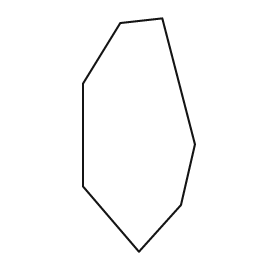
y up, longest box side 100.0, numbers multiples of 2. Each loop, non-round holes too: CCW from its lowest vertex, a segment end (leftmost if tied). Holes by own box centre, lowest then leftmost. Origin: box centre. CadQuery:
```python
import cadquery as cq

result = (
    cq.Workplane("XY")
    .moveTo(0.0, -50.0)
    .lineTo(18.0, -30.0)
    .lineTo(24.0, -4.0)
    .lineTo(10.0, 50.0)
    .lineTo(-8.0, 48.0)
    .lineTo(-24.0, 22.0)
    .lineTo(-24.0, -22.0)
    .close()
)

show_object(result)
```